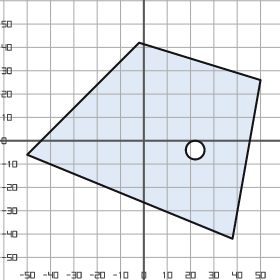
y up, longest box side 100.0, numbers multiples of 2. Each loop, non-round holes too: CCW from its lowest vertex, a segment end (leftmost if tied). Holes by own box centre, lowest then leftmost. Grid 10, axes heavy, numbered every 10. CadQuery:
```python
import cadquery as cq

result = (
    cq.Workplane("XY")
    .moveTo(38.0, -42.0)
    .lineTo(50.0, 26.0)
    .lineTo(-2.0, 42.0)
    .lineTo(-50.0, -6.0)
    .close()
    .moveTo(22.0, -4.0)
    .circle(4.0)
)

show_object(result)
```